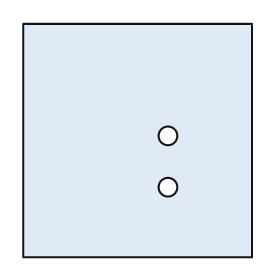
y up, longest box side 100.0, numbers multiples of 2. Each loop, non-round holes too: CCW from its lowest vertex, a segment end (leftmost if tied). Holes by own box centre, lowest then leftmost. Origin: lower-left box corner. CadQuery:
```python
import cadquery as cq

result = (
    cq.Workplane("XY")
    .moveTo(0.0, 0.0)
    .lineTo(98.0, 0.0)
    .lineTo(98.0, 100.0)
    .lineTo(0.0, 100.0)
    .close()
    .moveTo(62.0, 30.0)
    .circle(4.0)
    .moveTo(62.0, 52.0)
    .circle(4.0)
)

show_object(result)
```